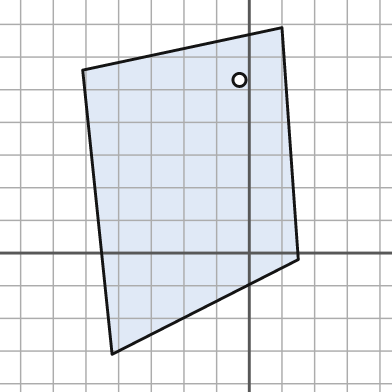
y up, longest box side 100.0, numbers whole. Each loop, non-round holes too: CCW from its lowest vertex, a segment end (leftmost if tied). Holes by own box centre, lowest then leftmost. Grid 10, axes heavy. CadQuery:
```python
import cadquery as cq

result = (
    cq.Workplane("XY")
    .moveTo(-42.0, -31.0)
    .lineTo(15.0, -2.0)
    .lineTo(10.0, 69.0)
    .lineTo(-51.0, 56.0)
    .close()
    .moveTo(-3.0, 53.0)
    .circle(2.0)
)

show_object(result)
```